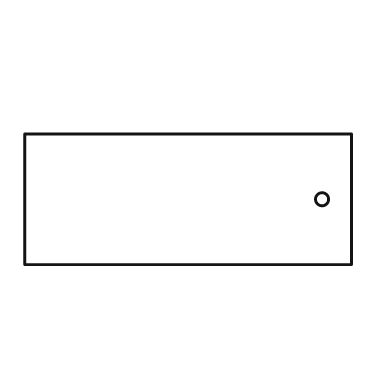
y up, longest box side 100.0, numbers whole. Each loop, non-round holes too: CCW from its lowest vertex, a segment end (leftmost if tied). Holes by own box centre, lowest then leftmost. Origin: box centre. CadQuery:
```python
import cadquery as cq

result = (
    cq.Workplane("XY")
    .moveTo(-50.0, -20.0)
    .lineTo(50.0, -20.0)
    .lineTo(50.0, 20.0)
    .lineTo(-50.0, 20.0)
    .close()
    .moveTo(41.0, 0.0)
    .circle(2.0)
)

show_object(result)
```